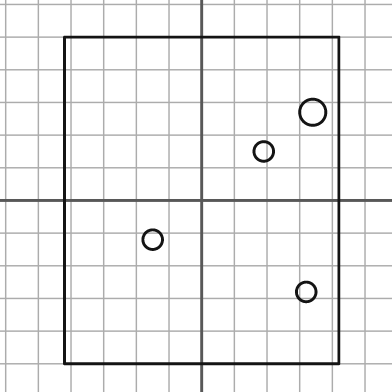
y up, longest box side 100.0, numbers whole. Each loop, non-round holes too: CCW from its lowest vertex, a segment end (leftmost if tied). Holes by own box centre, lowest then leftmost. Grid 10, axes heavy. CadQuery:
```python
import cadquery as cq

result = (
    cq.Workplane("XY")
    .moveTo(-42.0, -50.0)
    .lineTo(42.0, -50.0)
    .lineTo(42.0, 50.0)
    .lineTo(-42.0, 50.0)
    .close()
    .moveTo(32.0, -28.0)
    .circle(3.0)
    .moveTo(-15.0, -12.0)
    .circle(3.0)
    .moveTo(19.0, 15.0)
    .circle(3.0)
    .moveTo(34.0, 27.0)
    .circle(4.0)
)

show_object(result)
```